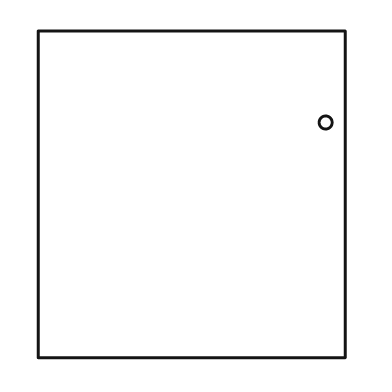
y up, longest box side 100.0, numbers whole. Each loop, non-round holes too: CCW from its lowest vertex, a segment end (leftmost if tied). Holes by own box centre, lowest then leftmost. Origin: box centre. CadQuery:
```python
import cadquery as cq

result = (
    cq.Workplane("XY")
    .moveTo(-47.0, -50.0)
    .lineTo(47.0, -50.0)
    .lineTo(47.0, 50.0)
    .lineTo(-47.0, 50.0)
    .close()
    .moveTo(41.0, 22.0)
    .circle(2.0)
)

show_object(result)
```